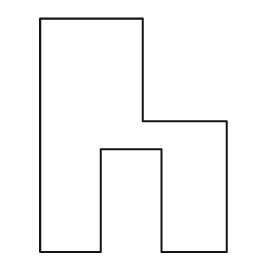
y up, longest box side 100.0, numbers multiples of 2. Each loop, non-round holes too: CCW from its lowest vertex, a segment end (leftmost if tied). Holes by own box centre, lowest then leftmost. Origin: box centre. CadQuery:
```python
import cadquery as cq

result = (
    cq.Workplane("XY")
    .moveTo(-40.0, -50.0)
    .lineTo(-14.0, -50.0)
    .lineTo(-14.0, -6.0)
    .lineTo(12.0, -6.0)
    .lineTo(12.0, -50.0)
    .lineTo(40.0, -50.0)
    .lineTo(40.0, 6.0)
    .lineTo(4.0, 6.0)
    .lineTo(4.0, 50.0)
    .lineTo(-40.0, 50.0)
    .close()
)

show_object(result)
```